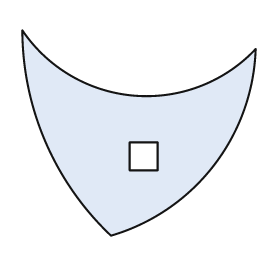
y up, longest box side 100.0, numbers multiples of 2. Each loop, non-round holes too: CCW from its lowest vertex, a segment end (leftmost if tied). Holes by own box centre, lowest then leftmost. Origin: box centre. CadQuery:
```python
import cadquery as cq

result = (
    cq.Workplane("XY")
    .moveTo(-12.0, -44.0)
    .threePointArc((32.0, -14.0), (50.0, 36.0))
    .threePointArc((-2.0, 16.0), (-50.0, 44.0))
    .threePointArc((-40.0, -4.0), (-12.0, -44.0))
    .close()
    .moveTo(-4.0, -16.0)
    .lineTo(8.0, -16.0)
    .lineTo(8.0, -4.0)
    .lineTo(-4.0, -4.0)
    .close()
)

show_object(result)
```